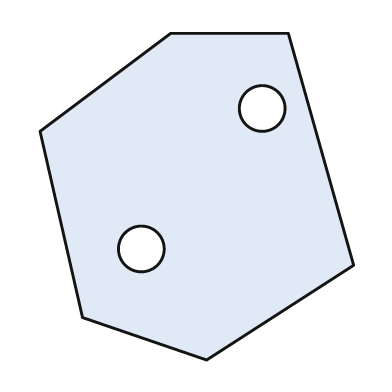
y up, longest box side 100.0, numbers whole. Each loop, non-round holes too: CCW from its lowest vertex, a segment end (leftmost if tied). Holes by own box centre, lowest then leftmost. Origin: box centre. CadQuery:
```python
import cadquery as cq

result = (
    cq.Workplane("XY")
    .moveTo(3.0, -50.0)
    .lineTo(48.0, -21.0)
    .lineTo(28.0, 50.0)
    .lineTo(-8.0, 50.0)
    .lineTo(-48.0, 20.0)
    .lineTo(-35.0, -37.0)
    .close()
    .moveTo(-17.0, -16.0)
    .circle(7.0)
    .moveTo(20.0, 27.0)
    .circle(7.0)
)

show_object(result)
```